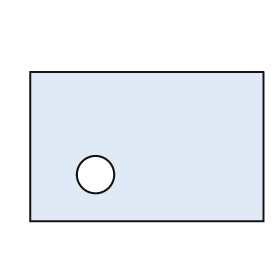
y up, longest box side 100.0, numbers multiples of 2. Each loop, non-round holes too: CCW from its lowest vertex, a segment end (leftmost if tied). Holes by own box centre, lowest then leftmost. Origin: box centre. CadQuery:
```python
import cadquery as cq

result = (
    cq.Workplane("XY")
    .moveTo(-50.0, -32.0)
    .lineTo(50.0, -32.0)
    .lineTo(50.0, 32.0)
    .lineTo(-50.0, 32.0)
    .close()
    .moveTo(-22.0, -12.0)
    .circle(8.0)
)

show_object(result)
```